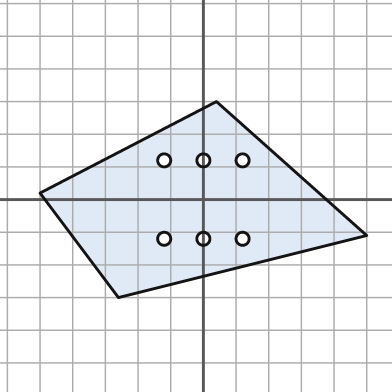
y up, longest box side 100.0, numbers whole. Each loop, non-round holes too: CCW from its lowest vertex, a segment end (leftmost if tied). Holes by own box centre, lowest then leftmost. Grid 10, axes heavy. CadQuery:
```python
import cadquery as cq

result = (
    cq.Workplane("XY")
    .moveTo(-26.0, -30.0)
    .lineTo(50.0, -11.0)
    .lineTo(4.0, 30.0)
    .lineTo(-50.0, 2.0)
    .close()
    .moveTo(-12.0, -12.0)
    .circle(2.0)
    .moveTo(0.0, -12.0)
    .circle(2.0)
    .moveTo(12.0, -12.0)
    .circle(2.0)
    .moveTo(-12.0, 12.0)
    .circle(2.0)
    .moveTo(0.0, 12.0)
    .circle(2.0)
    .moveTo(12.0, 12.0)
    .circle(2.0)
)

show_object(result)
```